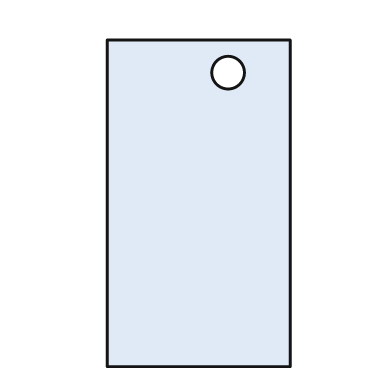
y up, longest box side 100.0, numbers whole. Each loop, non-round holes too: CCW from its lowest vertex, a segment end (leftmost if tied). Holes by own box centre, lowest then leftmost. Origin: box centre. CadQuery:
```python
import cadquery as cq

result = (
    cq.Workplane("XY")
    .moveTo(-28.0, -50.0)
    .lineTo(28.0, -50.0)
    .lineTo(28.0, 50.0)
    .lineTo(-28.0, 50.0)
    .close()
    .moveTo(9.0, 40.0)
    .circle(5.0)
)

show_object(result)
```